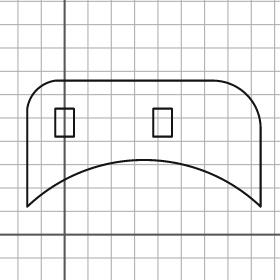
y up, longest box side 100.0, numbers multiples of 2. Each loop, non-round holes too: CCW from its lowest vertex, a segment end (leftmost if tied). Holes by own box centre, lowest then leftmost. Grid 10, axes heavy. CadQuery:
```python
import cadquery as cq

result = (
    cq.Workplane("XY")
    .moveTo(-16.0, 12.0)
    .threePointArc((34.0, 32.0), (84.0, 12.0))
    .lineTo(84.0, 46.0)
    .threePointArc((78.0, 60.0), (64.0, 66.0))
    .lineTo(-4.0, 66.0)
    .threePointArc((-12.0, 62.0), (-16.0, 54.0))
    .close()
    .moveTo(-4.0, 42.0)
    .lineTo(4.0, 42.0)
    .lineTo(4.0, 54.0)
    .lineTo(-4.0, 54.0)
    .close()
    .moveTo(38.0, 42.0)
    .lineTo(46.0, 42.0)
    .lineTo(46.0, 54.0)
    .lineTo(38.0, 54.0)
    .close()
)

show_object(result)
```